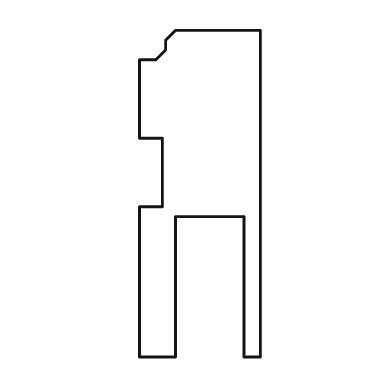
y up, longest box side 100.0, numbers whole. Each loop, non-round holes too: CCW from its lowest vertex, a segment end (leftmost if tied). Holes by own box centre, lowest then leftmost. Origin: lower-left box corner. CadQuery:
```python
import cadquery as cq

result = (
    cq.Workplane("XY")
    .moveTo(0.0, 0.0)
    .lineTo(11.0, 0.0)
    .lineTo(11.0, 43.0)
    .lineTo(32.0, 43.0)
    .lineTo(32.0, 0.0)
    .lineTo(37.0, 0.0)
    .lineTo(37.0, 100.0)
    .lineTo(11.0, 100.0)
    .lineTo(8.0, 97.0)
    .lineTo(8.0, 94.0)
    .lineTo(5.0, 91.0)
    .lineTo(0.0, 91.0)
    .lineTo(0.0, 67.0)
    .lineTo(7.0, 67.0)
    .lineTo(7.0, 46.0)
    .lineTo(0.0, 46.0)
    .close()
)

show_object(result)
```